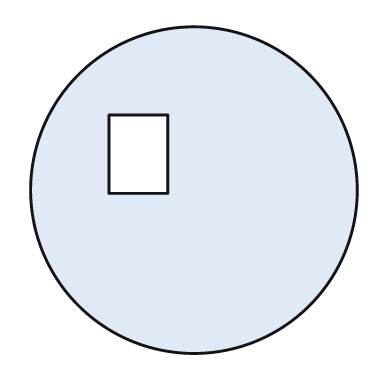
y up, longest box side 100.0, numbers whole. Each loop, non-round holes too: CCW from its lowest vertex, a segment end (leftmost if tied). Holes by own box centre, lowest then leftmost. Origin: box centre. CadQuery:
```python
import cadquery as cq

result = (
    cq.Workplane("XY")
    .moveTo(0.0, 0.0)
    .circle(50.0)
    .moveTo(-26.0, -1.0)
    .lineTo(-8.0, -1.0)
    .lineTo(-8.0, 23.0)
    .lineTo(-26.0, 23.0)
    .close()
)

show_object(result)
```